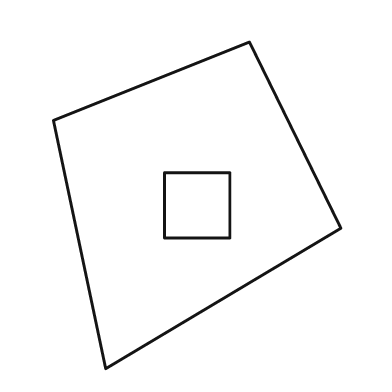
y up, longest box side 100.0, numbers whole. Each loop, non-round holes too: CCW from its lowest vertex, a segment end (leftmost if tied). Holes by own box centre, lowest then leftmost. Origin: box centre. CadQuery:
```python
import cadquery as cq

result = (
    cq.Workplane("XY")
    .moveTo(-28.0, -50.0)
    .lineTo(44.0, -7.0)
    .lineTo(16.0, 50.0)
    .lineTo(-44.0, 26.0)
    .close()
    .moveTo(-10.0, -10.0)
    .lineTo(10.0, -10.0)
    .lineTo(10.0, 10.0)
    .lineTo(-10.0, 10.0)
    .close()
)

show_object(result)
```